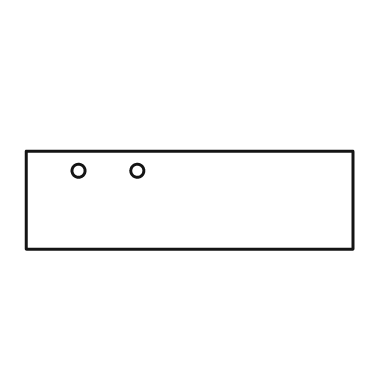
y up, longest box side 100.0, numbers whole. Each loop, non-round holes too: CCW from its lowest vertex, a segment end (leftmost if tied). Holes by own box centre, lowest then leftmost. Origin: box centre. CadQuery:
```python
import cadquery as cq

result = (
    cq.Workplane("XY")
    .moveTo(-50.0, -15.0)
    .lineTo(50.0, -15.0)
    .lineTo(50.0, 15.0)
    .lineTo(-50.0, 15.0)
    .close()
    .moveTo(-34.0, 9.0)
    .circle(2.0)
    .moveTo(-16.0, 9.0)
    .circle(2.0)
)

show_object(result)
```